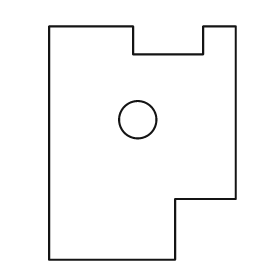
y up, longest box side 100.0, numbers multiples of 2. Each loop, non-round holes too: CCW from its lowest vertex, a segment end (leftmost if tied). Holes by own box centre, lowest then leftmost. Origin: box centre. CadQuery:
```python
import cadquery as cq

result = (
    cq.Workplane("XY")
    .moveTo(-40.0, -50.0)
    .lineTo(14.0, -50.0)
    .lineTo(14.0, -24.0)
    .lineTo(40.0, -24.0)
    .lineTo(40.0, 50.0)
    .lineTo(26.0, 50.0)
    .lineTo(26.0, 38.0)
    .lineTo(-4.0, 38.0)
    .lineTo(-4.0, 50.0)
    .lineTo(-40.0, 50.0)
    .close()
    .moveTo(-2.0, 10.0)
    .circle(8.0)
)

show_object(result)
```